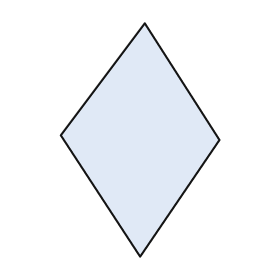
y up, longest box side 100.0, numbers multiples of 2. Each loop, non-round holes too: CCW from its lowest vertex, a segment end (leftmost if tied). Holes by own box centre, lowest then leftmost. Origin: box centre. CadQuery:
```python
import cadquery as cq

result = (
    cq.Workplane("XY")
    .moveTo(0.0, -50.0)
    .lineTo(34.0, 0.0)
    .lineTo(2.0, 50.0)
    .lineTo(-34.0, 2.0)
    .close()
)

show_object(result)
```